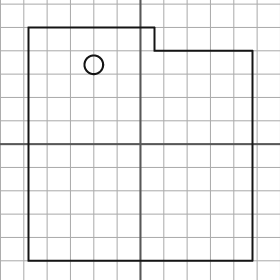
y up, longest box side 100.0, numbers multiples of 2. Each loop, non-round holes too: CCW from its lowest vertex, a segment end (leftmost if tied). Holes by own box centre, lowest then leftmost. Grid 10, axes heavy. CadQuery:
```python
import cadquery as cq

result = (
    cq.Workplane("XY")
    .moveTo(-48.0, -50.0)
    .lineTo(48.0, -50.0)
    .lineTo(48.0, 40.0)
    .lineTo(6.0, 40.0)
    .lineTo(6.0, 50.0)
    .lineTo(-48.0, 50.0)
    .close()
    .moveTo(-20.0, 34.0)
    .circle(4.0)
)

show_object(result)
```